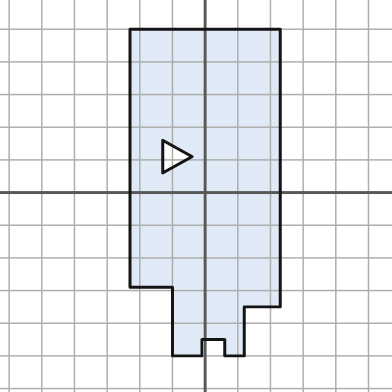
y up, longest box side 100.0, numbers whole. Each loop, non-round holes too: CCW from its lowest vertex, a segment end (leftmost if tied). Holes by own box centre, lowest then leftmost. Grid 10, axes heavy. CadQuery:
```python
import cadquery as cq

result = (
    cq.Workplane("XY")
    .moveTo(-10.0, -50.0)
    .lineTo(-1.0, -50.0)
    .lineTo(-1.0, -45.0)
    .lineTo(6.0, -45.0)
    .lineTo(6.0, -50.0)
    .lineTo(12.0, -50.0)
    .lineTo(12.0, -35.0)
    .lineTo(23.0, -35.0)
    .lineTo(23.0, 50.0)
    .lineTo(-23.0, 50.0)
    .lineTo(-23.0, -29.0)
    .lineTo(-10.0, -29.0)
    .close()
    .moveTo(-13.0, 6.0)
    .lineTo(-4.0, 11.0)
    .lineTo(-13.0, 16.0)
    .close()
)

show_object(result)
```